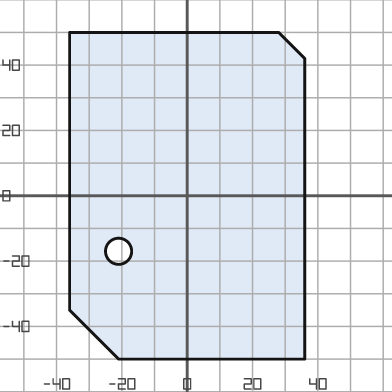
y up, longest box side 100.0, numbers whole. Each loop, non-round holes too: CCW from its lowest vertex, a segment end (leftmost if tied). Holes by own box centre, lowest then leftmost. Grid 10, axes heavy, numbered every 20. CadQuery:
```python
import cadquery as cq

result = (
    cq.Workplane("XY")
    .moveTo(-21.0, -50.0)
    .lineTo(36.0, -50.0)
    .lineTo(36.0, 42.0)
    .lineTo(28.0, 50.0)
    .lineTo(-36.0, 50.0)
    .lineTo(-36.0, -35.0)
    .close()
    .moveTo(-21.0, -17.0)
    .circle(4.0)
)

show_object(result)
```